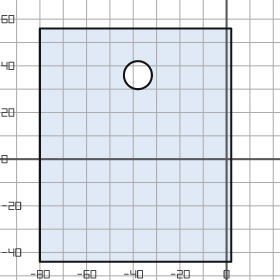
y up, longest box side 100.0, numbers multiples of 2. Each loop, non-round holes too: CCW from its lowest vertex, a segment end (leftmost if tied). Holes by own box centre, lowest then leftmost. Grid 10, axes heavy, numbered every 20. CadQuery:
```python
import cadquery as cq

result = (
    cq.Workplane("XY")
    .moveTo(-80.0, -44.0)
    .lineTo(2.0, -44.0)
    .lineTo(2.0, 56.0)
    .lineTo(-80.0, 56.0)
    .close()
    .moveTo(-38.0, 36.0)
    .circle(6.0)
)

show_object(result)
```